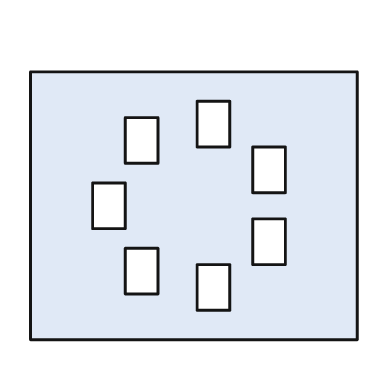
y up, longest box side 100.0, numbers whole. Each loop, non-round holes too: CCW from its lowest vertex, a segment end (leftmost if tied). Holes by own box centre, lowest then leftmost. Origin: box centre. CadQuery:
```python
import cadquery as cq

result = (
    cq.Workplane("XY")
    .moveTo(-50.0, -41.0)
    .lineTo(50.0, -41.0)
    .lineTo(50.0, 41.0)
    .lineTo(-50.0, 41.0)
    .close()
    .moveTo(1.0, -32.0)
    .lineTo(11.0, -32.0)
    .lineTo(11.0, -18.0)
    .lineTo(1.0, -18.0)
    .close()
    .moveTo(-21.0, -27.0)
    .lineTo(-11.0, -27.0)
    .lineTo(-11.0, -13.0)
    .lineTo(-21.0, -13.0)
    .close()
    .moveTo(18.0, -18.0)
    .lineTo(28.0, -18.0)
    .lineTo(28.0, -4.0)
    .lineTo(18.0, -4.0)
    .close()
    .moveTo(-31.0, -7.0)
    .lineTo(-21.0, -7.0)
    .lineTo(-21.0, 7.0)
    .lineTo(-31.0, 7.0)
    .close()
    .moveTo(18.0, 4.0)
    .lineTo(28.0, 4.0)
    .lineTo(28.0, 18.0)
    .lineTo(18.0, 18.0)
    .close()
    .moveTo(-21.0, 13.0)
    .lineTo(-11.0, 13.0)
    .lineTo(-11.0, 27.0)
    .lineTo(-21.0, 27.0)
    .close()
    .moveTo(1.0, 18.0)
    .lineTo(11.0, 18.0)
    .lineTo(11.0, 32.0)
    .lineTo(1.0, 32.0)
    .close()
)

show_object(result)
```